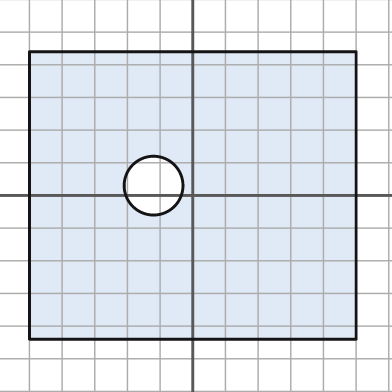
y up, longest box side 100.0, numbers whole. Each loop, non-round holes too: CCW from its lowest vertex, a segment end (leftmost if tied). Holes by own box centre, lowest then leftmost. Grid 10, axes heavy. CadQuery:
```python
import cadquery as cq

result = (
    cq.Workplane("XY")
    .moveTo(-50.0, -44.0)
    .lineTo(50.0, -44.0)
    .lineTo(50.0, 44.0)
    .lineTo(-50.0, 44.0)
    .close()
    .moveTo(-12.0, 3.0)
    .circle(9.0)
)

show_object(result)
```